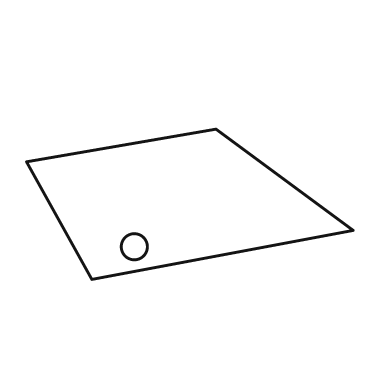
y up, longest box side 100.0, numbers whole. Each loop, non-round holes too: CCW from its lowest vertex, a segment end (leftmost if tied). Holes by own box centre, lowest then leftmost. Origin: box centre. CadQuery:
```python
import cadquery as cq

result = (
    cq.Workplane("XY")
    .moveTo(-30.0, -23.0)
    .lineTo(50.0, -8.0)
    .lineTo(8.0, 23.0)
    .lineTo(-50.0, 13.0)
    .close()
    .moveTo(-17.0, -13.0)
    .circle(4.0)
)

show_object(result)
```